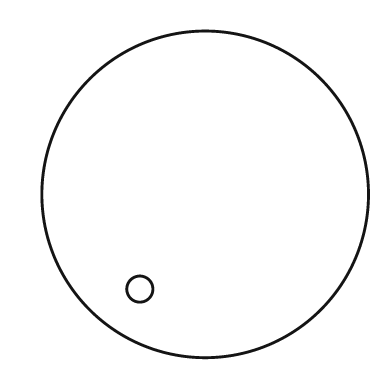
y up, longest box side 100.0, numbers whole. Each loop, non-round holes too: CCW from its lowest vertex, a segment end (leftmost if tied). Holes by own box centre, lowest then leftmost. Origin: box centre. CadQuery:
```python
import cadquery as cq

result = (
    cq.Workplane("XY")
    .moveTo(0.0, 0.0)
    .circle(50.0)
    .moveTo(-20.0, -29.0)
    .circle(4.0)
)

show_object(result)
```